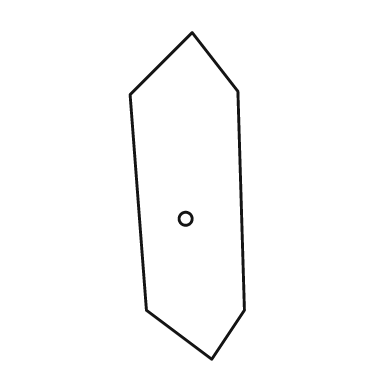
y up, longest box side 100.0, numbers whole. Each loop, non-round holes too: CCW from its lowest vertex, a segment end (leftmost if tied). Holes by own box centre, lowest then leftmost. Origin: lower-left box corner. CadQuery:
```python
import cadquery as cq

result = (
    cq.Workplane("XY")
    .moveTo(25.0, 0.0)
    .lineTo(35.0, 15.0)
    .lineTo(33.0, 82.0)
    .lineTo(19.0, 100.0)
    .lineTo(0.0, 81.0)
    .lineTo(5.0, 15.0)
    .close()
    .moveTo(17.0, 43.0)
    .circle(2.0)
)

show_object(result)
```